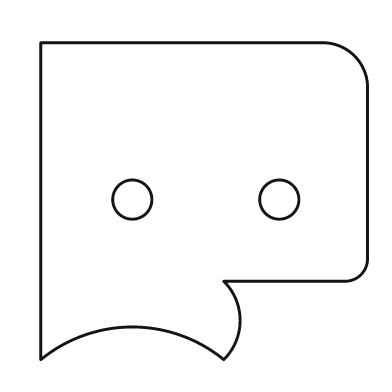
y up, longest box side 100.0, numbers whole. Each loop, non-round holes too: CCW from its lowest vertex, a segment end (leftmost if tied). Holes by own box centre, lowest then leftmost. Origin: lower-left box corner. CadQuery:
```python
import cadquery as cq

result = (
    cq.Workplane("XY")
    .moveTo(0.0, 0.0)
    .threePointArc((28.0, 10.0), (56.0, 0.0))
    .threePointArc((61.0, 12.0), (56.0, 24.0))
    .lineTo(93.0, 24.0)
    .threePointArc((98.0, 26.0), (100.0, 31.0))
    .lineTo(100.0, 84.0)
    .threePointArc((96.0, 93.0), (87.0, 97.0))
    .lineTo(0.0, 97.0)
    .close()
    .moveTo(28.0, 49.0)
    .circle(6.0)
    .moveTo(73.0, 49.0)
    .circle(6.0)
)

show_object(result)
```